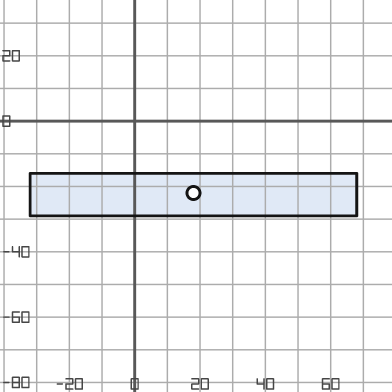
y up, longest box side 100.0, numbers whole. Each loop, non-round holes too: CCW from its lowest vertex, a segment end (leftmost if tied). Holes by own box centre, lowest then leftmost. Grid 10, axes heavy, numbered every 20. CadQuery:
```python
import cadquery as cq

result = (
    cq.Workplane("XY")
    .moveTo(-32.0, -29.0)
    .lineTo(68.0, -29.0)
    .lineTo(68.0, -16.0)
    .lineTo(-32.0, -16.0)
    .close()
    .moveTo(18.0, -22.0)
    .circle(2.0)
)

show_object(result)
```